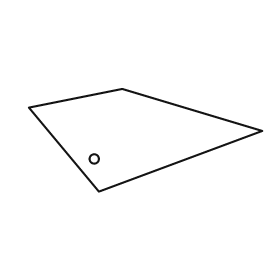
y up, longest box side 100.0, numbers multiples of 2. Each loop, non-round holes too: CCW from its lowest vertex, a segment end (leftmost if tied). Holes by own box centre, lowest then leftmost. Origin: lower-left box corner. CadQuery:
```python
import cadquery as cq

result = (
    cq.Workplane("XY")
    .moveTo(30.0, 0.0)
    .lineTo(100.0, 26.0)
    .lineTo(40.0, 44.0)
    .lineTo(0.0, 36.0)
    .close()
    .moveTo(28.0, 14.0)
    .circle(2.0)
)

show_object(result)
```